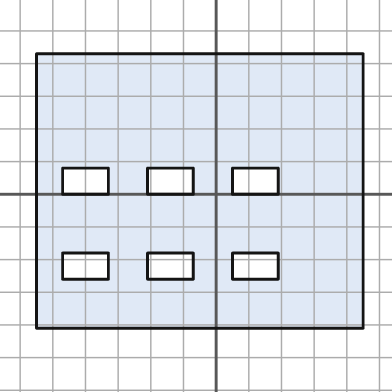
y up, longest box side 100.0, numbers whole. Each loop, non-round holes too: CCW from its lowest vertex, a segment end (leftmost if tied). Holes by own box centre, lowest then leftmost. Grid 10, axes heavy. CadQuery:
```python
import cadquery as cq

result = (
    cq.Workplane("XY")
    .moveTo(-55.0, -41.0)
    .lineTo(45.0, -41.0)
    .lineTo(45.0, 43.0)
    .lineTo(-55.0, 43.0)
    .close()
    .moveTo(-47.0, -26.0)
    .lineTo(-33.0, -26.0)
    .lineTo(-33.0, -18.0)
    .lineTo(-47.0, -18.0)
    .close()
    .moveTo(-21.0, -26.0)
    .lineTo(-7.0, -26.0)
    .lineTo(-7.0, -18.0)
    .lineTo(-21.0, -18.0)
    .close()
    .moveTo(5.0, -26.0)
    .lineTo(19.0, -26.0)
    .lineTo(19.0, -18.0)
    .lineTo(5.0, -18.0)
    .close()
    .moveTo(-47.0, 0.0)
    .lineTo(-33.0, 0.0)
    .lineTo(-33.0, 8.0)
    .lineTo(-47.0, 8.0)
    .close()
    .moveTo(-21.0, 0.0)
    .lineTo(-7.0, 0.0)
    .lineTo(-7.0, 8.0)
    .lineTo(-21.0, 8.0)
    .close()
    .moveTo(5.0, 0.0)
    .lineTo(19.0, 0.0)
    .lineTo(19.0, 8.0)
    .lineTo(5.0, 8.0)
    .close()
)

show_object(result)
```